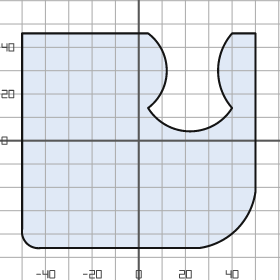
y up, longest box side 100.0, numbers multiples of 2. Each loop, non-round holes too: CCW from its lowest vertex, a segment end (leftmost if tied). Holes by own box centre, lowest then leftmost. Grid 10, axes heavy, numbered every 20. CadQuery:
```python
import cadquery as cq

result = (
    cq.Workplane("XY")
    .moveTo(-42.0, -46.0)
    .lineTo(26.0, -46.0)
    .threePointArc((42.0, -38.0), (50.0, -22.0))
    .lineTo(50.0, 46.0)
    .lineTo(40.0, 46.0)
    .threePointArc((34.0, 30.0), (40.0, 14.0))
    .threePointArc((22.0, 4.0), (4.0, 14.0))
    .threePointArc((12.0, 30.0), (4.0, 46.0))
    .lineTo(-50.0, 46.0)
    .lineTo(-50.0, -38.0)
    .threePointArc((-48.0, -44.0), (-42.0, -46.0))
    .close()
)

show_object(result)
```